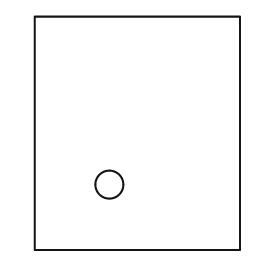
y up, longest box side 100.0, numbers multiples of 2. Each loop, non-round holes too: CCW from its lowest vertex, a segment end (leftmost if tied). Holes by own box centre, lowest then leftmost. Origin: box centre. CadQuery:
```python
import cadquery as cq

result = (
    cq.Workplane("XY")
    .moveTo(-44.0, -50.0)
    .lineTo(44.0, -50.0)
    .lineTo(44.0, 50.0)
    .lineTo(-44.0, 50.0)
    .close()
    .moveTo(-12.0, -22.0)
    .circle(6.0)
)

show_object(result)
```